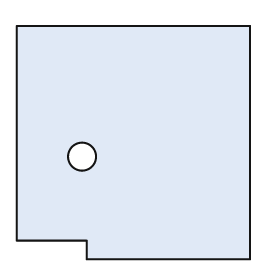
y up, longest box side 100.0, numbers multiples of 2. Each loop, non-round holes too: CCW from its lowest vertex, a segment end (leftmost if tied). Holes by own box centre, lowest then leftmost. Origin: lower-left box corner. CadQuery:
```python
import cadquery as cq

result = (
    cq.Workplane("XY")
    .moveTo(30.0, 0.0)
    .lineTo(100.0, 0.0)
    .lineTo(100.0, 100.0)
    .lineTo(0.0, 100.0)
    .lineTo(0.0, 8.0)
    .lineTo(30.0, 8.0)
    .close()
    .moveTo(28.0, 44.0)
    .circle(6.0)
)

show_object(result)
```